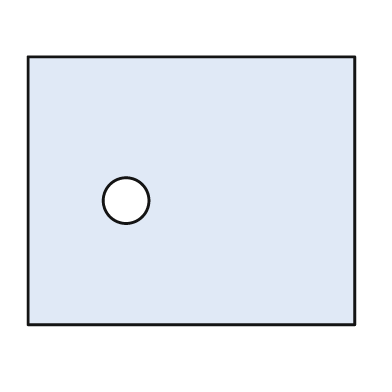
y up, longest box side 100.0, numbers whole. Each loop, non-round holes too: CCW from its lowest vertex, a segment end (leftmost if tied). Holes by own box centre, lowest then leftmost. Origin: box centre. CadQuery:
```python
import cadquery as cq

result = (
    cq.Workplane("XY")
    .moveTo(-50.0, -41.0)
    .lineTo(50.0, -41.0)
    .lineTo(50.0, 41.0)
    .lineTo(-50.0, 41.0)
    .close()
    .moveTo(-20.0, -3.0)
    .circle(7.0)
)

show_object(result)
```